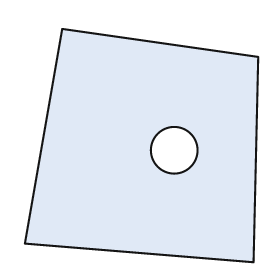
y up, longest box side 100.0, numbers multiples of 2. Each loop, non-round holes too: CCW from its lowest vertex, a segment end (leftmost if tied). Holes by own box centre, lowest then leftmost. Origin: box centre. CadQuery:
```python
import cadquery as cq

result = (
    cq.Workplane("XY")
    .moveTo(48.0, -50.0)
    .lineTo(50.0, 38.0)
    .lineTo(-34.0, 50.0)
    .lineTo(-50.0, -42.0)
    .close()
    .moveTo(14.0, -2.0)
    .circle(10.0)
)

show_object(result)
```